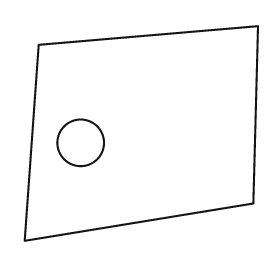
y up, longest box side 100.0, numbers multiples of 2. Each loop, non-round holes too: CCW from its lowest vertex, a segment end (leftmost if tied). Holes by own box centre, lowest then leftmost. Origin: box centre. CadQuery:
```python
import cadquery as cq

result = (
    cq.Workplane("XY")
    .moveTo(-50.0, -46.0)
    .lineTo(48.0, -30.0)
    .lineTo(50.0, 46.0)
    .lineTo(-44.0, 38.0)
    .close()
    .moveTo(-26.0, -4.0)
    .circle(10.0)
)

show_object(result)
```